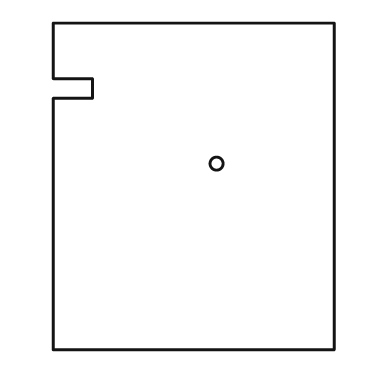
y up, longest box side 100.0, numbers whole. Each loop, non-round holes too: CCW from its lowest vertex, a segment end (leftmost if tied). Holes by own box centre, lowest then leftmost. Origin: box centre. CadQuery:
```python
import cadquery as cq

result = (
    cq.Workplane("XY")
    .moveTo(-43.0, -50.0)
    .lineTo(43.0, -50.0)
    .lineTo(43.0, 50.0)
    .lineTo(-43.0, 50.0)
    .lineTo(-43.0, 33.0)
    .lineTo(-31.0, 33.0)
    .lineTo(-31.0, 27.0)
    .lineTo(-43.0, 27.0)
    .close()
    .moveTo(7.0, 7.0)
    .circle(2.0)
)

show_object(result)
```